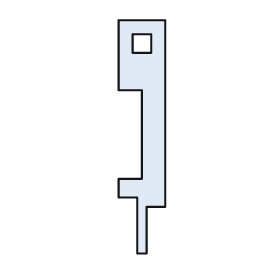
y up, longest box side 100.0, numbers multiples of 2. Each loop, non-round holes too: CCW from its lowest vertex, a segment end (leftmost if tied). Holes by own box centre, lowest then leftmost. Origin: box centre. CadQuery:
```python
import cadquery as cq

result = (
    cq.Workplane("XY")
    .moveTo(-2.0, -50.0)
    .lineTo(2.0, -50.0)
    .lineTo(2.0, -30.0)
    .lineTo(10.0, -30.0)
    .lineTo(10.0, 50.0)
    .lineTo(-10.0, 50.0)
    .lineTo(-10.0, 20.0)
    .lineTo(0.0, 20.0)
    .lineTo(0.0, -18.0)
    .lineTo(-10.0, -18.0)
    .lineTo(-10.0, -26.0)
    .lineTo(-2.0, -26.0)
    .close()
    .moveTo(-4.0, 36.0)
    .lineTo(4.0, 36.0)
    .lineTo(4.0, 44.0)
    .lineTo(-4.0, 44.0)
    .close()
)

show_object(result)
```